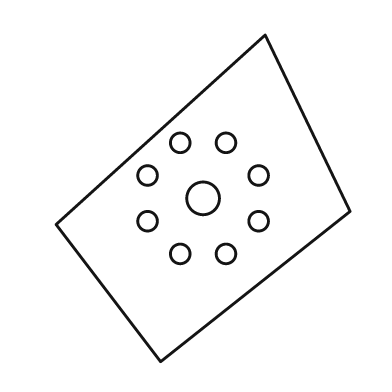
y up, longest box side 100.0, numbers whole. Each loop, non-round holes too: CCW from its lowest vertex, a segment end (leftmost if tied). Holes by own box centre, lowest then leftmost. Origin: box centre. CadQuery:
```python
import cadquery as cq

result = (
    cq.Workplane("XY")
    .moveTo(-13.0, -50.0)
    .lineTo(45.0, -4.0)
    .lineTo(19.0, 50.0)
    .lineTo(-45.0, -8.0)
    .close()
    .moveTo(-7.0, -17.0)
    .circle(3.0)
    .moveTo(7.0, -17.0)
    .circle(3.0)
    .moveTo(-17.0, -7.0)
    .circle(3.0)
    .moveTo(17.0, -7.0)
    .circle(3.0)
    .moveTo(0.0, 0.0)
    .circle(5.0)
    .moveTo(-17.0, 7.0)
    .circle(3.0)
    .moveTo(17.0, 7.0)
    .circle(3.0)
    .moveTo(-7.0, 17.0)
    .circle(3.0)
    .moveTo(7.0, 17.0)
    .circle(3.0)
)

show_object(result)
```